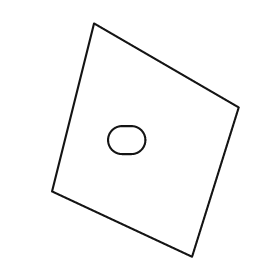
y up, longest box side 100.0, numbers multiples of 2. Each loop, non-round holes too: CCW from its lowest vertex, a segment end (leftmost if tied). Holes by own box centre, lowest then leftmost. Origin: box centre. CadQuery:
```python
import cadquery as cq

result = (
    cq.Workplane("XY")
    .moveTo(20.0, -50.0)
    .lineTo(40.0, 14.0)
    .lineTo(-22.0, 50.0)
    .lineTo(-40.0, -22.0)
    .close()
    .moveTo(-10.0, -6.0)
    .lineTo(-6.0, -6.0)
    .threePointArc((0.0, 0.0), (-6.0, 6.0))
    .lineTo(-10.0, 6.0)
    .threePointArc((-16.0, 0.0), (-10.0, -6.0))
    .close()
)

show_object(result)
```